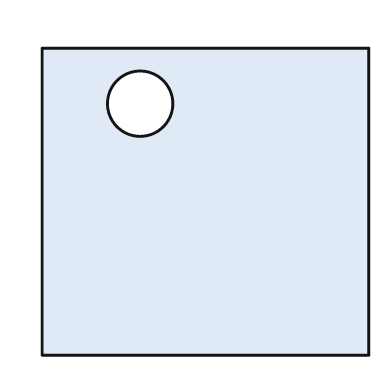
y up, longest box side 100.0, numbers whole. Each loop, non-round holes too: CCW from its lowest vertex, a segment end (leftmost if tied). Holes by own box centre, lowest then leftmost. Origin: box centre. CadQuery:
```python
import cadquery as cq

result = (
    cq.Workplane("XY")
    .moveTo(-50.0, -47.0)
    .lineTo(50.0, -47.0)
    .lineTo(50.0, 47.0)
    .lineTo(-50.0, 47.0)
    .close()
    .moveTo(-20.0, 30.0)
    .circle(10.0)
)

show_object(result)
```